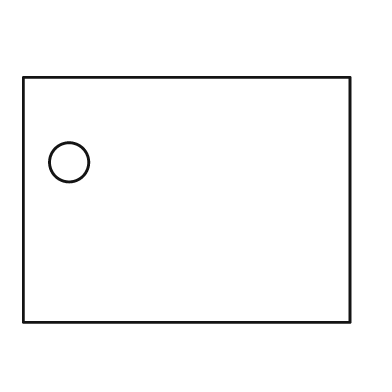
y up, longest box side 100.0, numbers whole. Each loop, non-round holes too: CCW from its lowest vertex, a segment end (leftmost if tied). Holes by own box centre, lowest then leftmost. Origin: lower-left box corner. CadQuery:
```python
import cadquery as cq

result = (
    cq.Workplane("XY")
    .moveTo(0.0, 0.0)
    .lineTo(100.0, 0.0)
    .lineTo(100.0, 75.0)
    .lineTo(0.0, 75.0)
    .close()
    .moveTo(14.0, 49.0)
    .circle(6.0)
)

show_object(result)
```